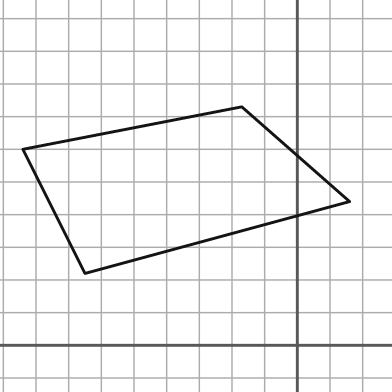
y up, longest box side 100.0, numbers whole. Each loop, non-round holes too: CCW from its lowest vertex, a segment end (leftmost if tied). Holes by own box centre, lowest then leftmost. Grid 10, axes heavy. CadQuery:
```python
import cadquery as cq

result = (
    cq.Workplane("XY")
    .moveTo(-65.0, 22.0)
    .lineTo(16.0, 44.0)
    .lineTo(-17.0, 73.0)
    .lineTo(-84.0, 60.0)
    .close()
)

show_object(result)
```